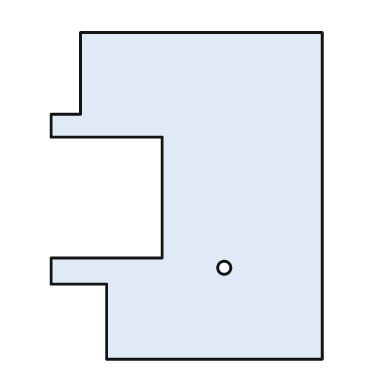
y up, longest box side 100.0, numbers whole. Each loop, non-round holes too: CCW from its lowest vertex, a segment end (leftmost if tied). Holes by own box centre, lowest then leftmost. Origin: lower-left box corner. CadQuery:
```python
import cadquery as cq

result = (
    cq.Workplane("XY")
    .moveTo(17.0, 0.0)
    .lineTo(83.0, 0.0)
    .lineTo(83.0, 100.0)
    .lineTo(9.0, 100.0)
    .lineTo(9.0, 75.0)
    .lineTo(0.0, 75.0)
    .lineTo(0.0, 68.0)
    .lineTo(34.0, 68.0)
    .lineTo(34.0, 31.0)
    .lineTo(0.0, 31.0)
    .lineTo(0.0, 23.0)
    .lineTo(17.0, 23.0)
    .close()
    .moveTo(53.0, 28.0)
    .circle(2.0)
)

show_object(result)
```